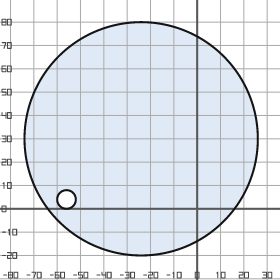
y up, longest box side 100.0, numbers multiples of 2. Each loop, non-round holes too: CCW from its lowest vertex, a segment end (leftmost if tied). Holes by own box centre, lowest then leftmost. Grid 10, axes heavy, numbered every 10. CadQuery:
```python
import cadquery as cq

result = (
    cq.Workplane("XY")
    .moveTo(-24.0, 30.0)
    .circle(50.0)
    .moveTo(-56.0, 4.0)
    .circle(4.0)
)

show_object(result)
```